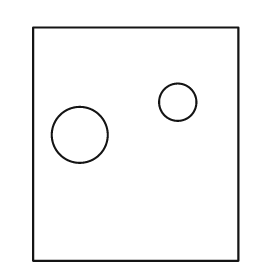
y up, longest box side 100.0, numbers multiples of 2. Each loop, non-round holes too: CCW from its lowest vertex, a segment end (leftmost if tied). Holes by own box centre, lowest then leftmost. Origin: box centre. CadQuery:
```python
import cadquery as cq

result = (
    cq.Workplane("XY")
    .moveTo(-44.0, -50.0)
    .lineTo(44.0, -50.0)
    .lineTo(44.0, 50.0)
    .lineTo(-44.0, 50.0)
    .close()
    .moveTo(-24.0, 4.0)
    .circle(12.0)
    .moveTo(18.0, 18.0)
    .circle(8.0)
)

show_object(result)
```